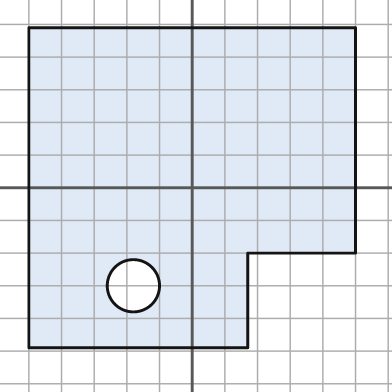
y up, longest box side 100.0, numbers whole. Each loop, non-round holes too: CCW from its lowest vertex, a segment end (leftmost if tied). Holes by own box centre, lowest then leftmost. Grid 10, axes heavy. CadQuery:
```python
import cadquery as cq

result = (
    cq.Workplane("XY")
    .moveTo(-50.0, -49.0)
    .lineTo(17.0, -49.0)
    .lineTo(17.0, -20.0)
    .lineTo(50.0, -20.0)
    .lineTo(50.0, 49.0)
    .lineTo(-50.0, 49.0)
    .close()
    .moveTo(-18.0, -30.0)
    .circle(8.0)
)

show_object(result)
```